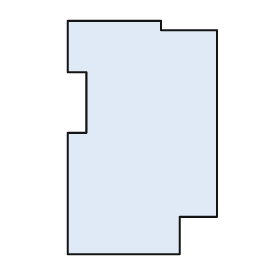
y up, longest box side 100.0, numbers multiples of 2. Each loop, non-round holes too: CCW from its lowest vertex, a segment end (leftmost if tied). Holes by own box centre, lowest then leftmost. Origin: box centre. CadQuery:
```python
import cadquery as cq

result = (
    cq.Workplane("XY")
    .moveTo(-32.0, -50.0)
    .lineTo(16.0, -50.0)
    .lineTo(16.0, -34.0)
    .lineTo(32.0, -34.0)
    .lineTo(32.0, 46.0)
    .lineTo(8.0, 46.0)
    .lineTo(8.0, 50.0)
    .lineTo(-32.0, 50.0)
    .lineTo(-32.0, 28.0)
    .lineTo(-24.0, 28.0)
    .lineTo(-24.0, 2.0)
    .lineTo(-32.0, 2.0)
    .close()
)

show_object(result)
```